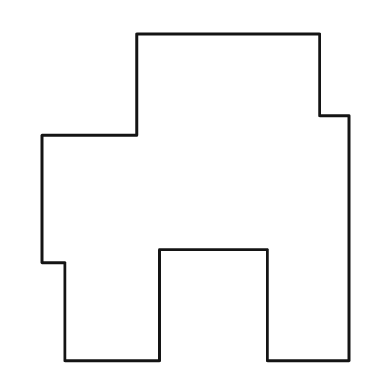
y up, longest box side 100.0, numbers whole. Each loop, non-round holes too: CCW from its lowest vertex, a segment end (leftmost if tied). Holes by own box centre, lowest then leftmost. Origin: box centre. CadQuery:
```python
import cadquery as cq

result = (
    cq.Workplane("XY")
    .moveTo(-40.0, -50.0)
    .lineTo(-11.0, -50.0)
    .lineTo(-11.0, -16.0)
    .lineTo(22.0, -16.0)
    .lineTo(22.0, -50.0)
    .lineTo(47.0, -50.0)
    .lineTo(47.0, 25.0)
    .lineTo(38.0, 25.0)
    .lineTo(38.0, 50.0)
    .lineTo(-18.0, 50.0)
    .lineTo(-18.0, 19.0)
    .lineTo(-47.0, 19.0)
    .lineTo(-47.0, -20.0)
    .lineTo(-40.0, -20.0)
    .close()
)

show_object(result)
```